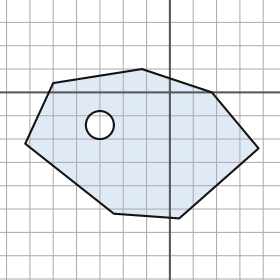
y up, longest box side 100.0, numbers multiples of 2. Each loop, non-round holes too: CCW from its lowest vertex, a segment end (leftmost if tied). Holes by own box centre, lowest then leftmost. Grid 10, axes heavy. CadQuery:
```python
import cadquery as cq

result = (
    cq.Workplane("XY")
    .moveTo(4.0, -54.0)
    .lineTo(38.0, -24.0)
    .lineTo(18.0, 0.0)
    .lineTo(-12.0, 10.0)
    .lineTo(-50.0, 4.0)
    .lineTo(-62.0, -22.0)
    .lineTo(-24.0, -52.0)
    .close()
    .moveTo(-30.0, -14.0)
    .circle(6.0)
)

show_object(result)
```